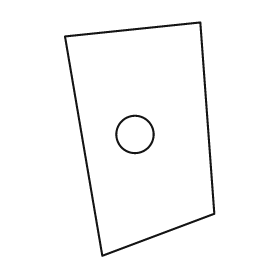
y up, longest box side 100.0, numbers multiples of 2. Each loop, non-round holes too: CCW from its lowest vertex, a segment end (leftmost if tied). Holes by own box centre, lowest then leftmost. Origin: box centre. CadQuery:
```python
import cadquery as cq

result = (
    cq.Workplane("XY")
    .moveTo(-16.0, -50.0)
    .lineTo(32.0, -32.0)
    .lineTo(26.0, 50.0)
    .lineTo(-32.0, 44.0)
    .close()
    .moveTo(-2.0, 2.0)
    .circle(8.0)
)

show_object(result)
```